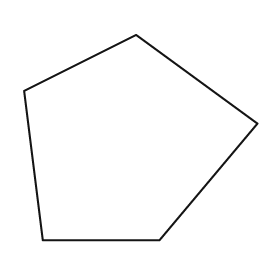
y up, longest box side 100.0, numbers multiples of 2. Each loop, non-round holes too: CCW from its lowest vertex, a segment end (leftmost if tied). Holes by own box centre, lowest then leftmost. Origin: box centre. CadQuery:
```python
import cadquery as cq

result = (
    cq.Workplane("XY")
    .moveTo(-42.0, -44.0)
    .lineTo(8.0, -44.0)
    .lineTo(50.0, 6.0)
    .lineTo(-2.0, 44.0)
    .lineTo(-50.0, 20.0)
    .close()
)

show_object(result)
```